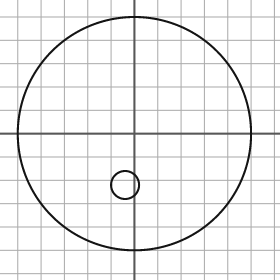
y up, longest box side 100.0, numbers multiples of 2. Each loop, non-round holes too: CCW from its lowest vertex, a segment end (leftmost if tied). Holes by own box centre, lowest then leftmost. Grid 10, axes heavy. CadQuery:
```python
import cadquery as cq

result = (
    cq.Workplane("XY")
    .moveTo(0.0, 0.0)
    .circle(50.0)
    .moveTo(-4.0, -22.0)
    .circle(6.0)
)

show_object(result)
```